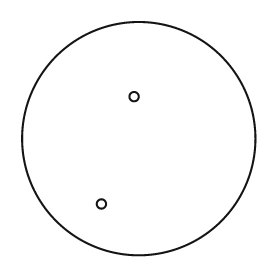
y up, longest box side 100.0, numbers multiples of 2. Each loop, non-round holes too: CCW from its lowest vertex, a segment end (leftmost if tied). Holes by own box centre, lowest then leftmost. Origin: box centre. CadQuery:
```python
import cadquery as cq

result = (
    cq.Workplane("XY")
    .moveTo(0.0, 0.0)
    .circle(50.0)
    .moveTo(-16.0, -28.0)
    .circle(2.0)
    .moveTo(-2.0, 18.0)
    .circle(2.0)
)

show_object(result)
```